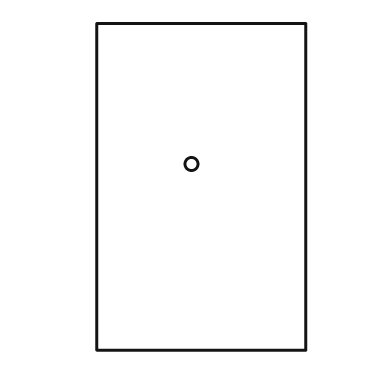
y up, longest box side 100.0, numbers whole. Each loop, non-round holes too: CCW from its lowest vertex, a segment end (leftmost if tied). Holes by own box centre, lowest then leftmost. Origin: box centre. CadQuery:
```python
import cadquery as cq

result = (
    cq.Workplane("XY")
    .moveTo(-32.0, -50.0)
    .lineTo(32.0, -50.0)
    .lineTo(32.0, 50.0)
    .lineTo(-32.0, 50.0)
    .close()
    .moveTo(-3.0, 7.0)
    .circle(2.0)
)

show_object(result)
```